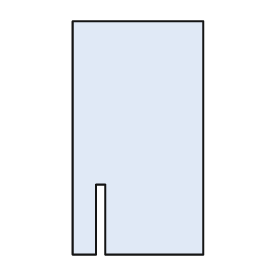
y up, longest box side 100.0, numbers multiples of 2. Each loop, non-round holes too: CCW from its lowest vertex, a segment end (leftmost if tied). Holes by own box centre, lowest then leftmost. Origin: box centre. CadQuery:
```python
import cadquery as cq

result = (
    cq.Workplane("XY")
    .moveTo(-28.0, -50.0)
    .lineTo(-18.0, -50.0)
    .lineTo(-18.0, -20.0)
    .lineTo(-14.0, -20.0)
    .lineTo(-14.0, -50.0)
    .lineTo(28.0, -50.0)
    .lineTo(28.0, 50.0)
    .lineTo(-28.0, 50.0)
    .close()
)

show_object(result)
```